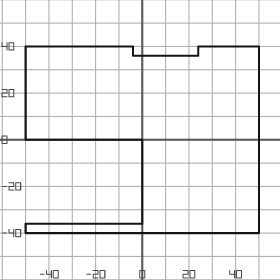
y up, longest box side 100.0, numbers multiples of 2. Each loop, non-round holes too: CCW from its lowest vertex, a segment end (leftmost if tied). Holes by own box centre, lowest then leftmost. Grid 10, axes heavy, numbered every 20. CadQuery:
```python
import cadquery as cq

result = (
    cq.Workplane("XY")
    .moveTo(-50.0, -40.0)
    .lineTo(50.0, -40.0)
    .lineTo(50.0, 40.0)
    .lineTo(24.0, 40.0)
    .lineTo(24.0, 36.0)
    .lineTo(-4.0, 36.0)
    .lineTo(-4.0, 40.0)
    .lineTo(-50.0, 40.0)
    .lineTo(-50.0, 0.0)
    .lineTo(0.0, 0.0)
    .lineTo(0.0, -36.0)
    .lineTo(-50.0, -36.0)
    .close()
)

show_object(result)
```